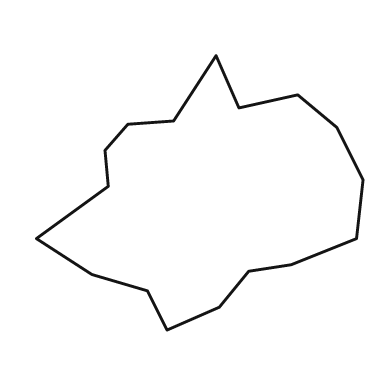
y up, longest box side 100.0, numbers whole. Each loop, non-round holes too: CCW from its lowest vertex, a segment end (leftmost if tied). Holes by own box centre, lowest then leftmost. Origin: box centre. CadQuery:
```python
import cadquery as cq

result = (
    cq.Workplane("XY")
    .moveTo(-10.0, -42.0)
    .lineTo(6.0, -35.0)
    .lineTo(15.0, -24.0)
    .lineTo(28.0, -22.0)
    .lineTo(48.0, -14.0)
    .lineTo(50.0, 4.0)
    .lineTo(42.0, 20.0)
    .lineTo(30.0, 30.0)
    .lineTo(12.0, 26.0)
    .lineTo(5.0, 42.0)
    .lineTo(-8.0, 22.0)
    .lineTo(-22.0, 21.0)
    .lineTo(-29.0, 13.0)
    .lineTo(-28.0, 2.0)
    .lineTo(-50.0, -14.0)
    .lineTo(-33.0, -25.0)
    .lineTo(-16.0, -30.0)
    .close()
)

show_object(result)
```